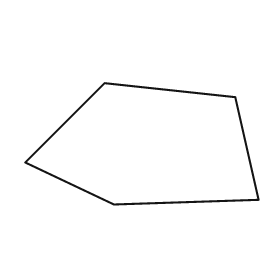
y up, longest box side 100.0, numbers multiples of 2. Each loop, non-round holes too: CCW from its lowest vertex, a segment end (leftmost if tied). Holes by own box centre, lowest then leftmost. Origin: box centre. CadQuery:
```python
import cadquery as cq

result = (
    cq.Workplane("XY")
    .moveTo(-12.0, -26.0)
    .lineTo(50.0, -24.0)
    .lineTo(40.0, 20.0)
    .lineTo(-16.0, 26.0)
    .lineTo(-50.0, -8.0)
    .close()
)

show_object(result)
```